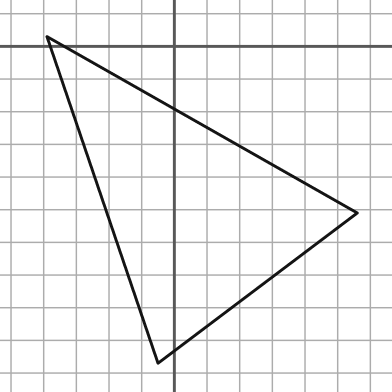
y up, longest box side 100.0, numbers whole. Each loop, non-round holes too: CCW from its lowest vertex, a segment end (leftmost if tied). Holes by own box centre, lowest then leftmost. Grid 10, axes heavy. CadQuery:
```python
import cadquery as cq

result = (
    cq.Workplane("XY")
    .moveTo(-5.0, -97.0)
    .lineTo(56.0, -51.0)
    .lineTo(-39.0, 3.0)
    .close()
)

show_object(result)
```